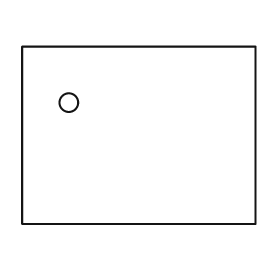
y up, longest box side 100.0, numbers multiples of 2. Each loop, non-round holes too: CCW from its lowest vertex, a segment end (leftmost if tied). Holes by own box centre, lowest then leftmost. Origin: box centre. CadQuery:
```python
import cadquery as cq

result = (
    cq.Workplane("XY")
    .moveTo(-50.0, -38.0)
    .lineTo(50.0, -38.0)
    .lineTo(50.0, 38.0)
    .lineTo(-50.0, 38.0)
    .close()
    .moveTo(-30.0, 14.0)
    .circle(4.0)
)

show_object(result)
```